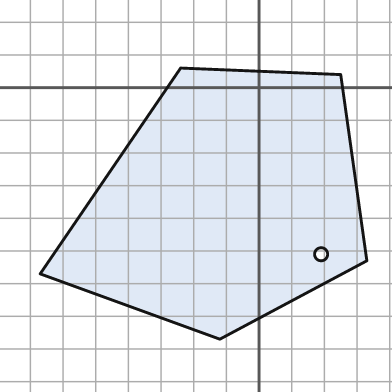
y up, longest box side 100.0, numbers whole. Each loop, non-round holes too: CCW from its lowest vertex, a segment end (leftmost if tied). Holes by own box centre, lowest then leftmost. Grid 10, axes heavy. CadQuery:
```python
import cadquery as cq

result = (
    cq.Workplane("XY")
    .moveTo(-12.0, -77.0)
    .lineTo(33.0, -53.0)
    .lineTo(25.0, 4.0)
    .lineTo(-24.0, 6.0)
    .lineTo(-67.0, -57.0)
    .close()
    .moveTo(19.0, -51.0)
    .circle(2.0)
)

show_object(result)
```